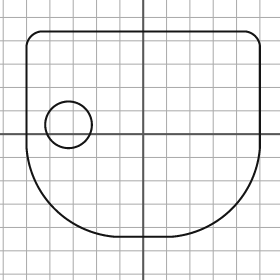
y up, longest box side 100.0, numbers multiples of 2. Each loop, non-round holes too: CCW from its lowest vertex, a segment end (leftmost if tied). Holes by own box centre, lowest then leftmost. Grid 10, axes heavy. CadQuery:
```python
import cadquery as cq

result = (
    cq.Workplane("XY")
    .moveTo(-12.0, -44.0)
    .lineTo(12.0, -44.0)
    .threePointArc((38.0, -32.0), (50.0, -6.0))
    .lineTo(50.0, 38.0)
    .threePointArc((48.0, 42.0), (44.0, 44.0))
    .lineTo(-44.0, 44.0)
    .threePointArc((-48.0, 42.0), (-50.0, 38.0))
    .lineTo(-50.0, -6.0)
    .threePointArc((-38.0, -32.0), (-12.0, -44.0))
    .close()
    .moveTo(-32.0, 4.0)
    .circle(10.0)
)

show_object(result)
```